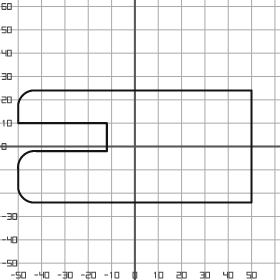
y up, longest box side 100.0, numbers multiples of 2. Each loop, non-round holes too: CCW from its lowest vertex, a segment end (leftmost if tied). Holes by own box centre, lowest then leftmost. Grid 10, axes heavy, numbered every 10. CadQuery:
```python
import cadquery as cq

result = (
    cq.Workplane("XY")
    .moveTo(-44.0, -24.0)
    .lineTo(50.0, -24.0)
    .lineTo(50.0, 24.0)
    .lineTo(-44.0, 24.0)
    .threePointArc((-48.0, 22.0), (-50.0, 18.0))
    .lineTo(-50.0, 10.0)
    .lineTo(-12.0, 10.0)
    .lineTo(-12.0, -2.0)
    .lineTo(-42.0, -2.0)
    .threePointArc((-48.0, -4.0), (-50.0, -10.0))
    .lineTo(-50.0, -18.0)
    .threePointArc((-48.0, -22.0), (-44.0, -24.0))
    .close()
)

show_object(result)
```